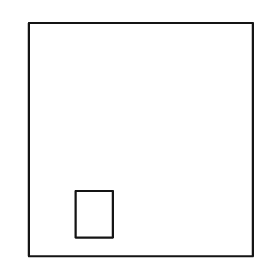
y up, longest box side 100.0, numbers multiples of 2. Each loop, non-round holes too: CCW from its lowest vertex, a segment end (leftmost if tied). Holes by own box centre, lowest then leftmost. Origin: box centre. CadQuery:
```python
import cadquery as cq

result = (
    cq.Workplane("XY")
    .moveTo(-48.0, -50.0)
    .lineTo(48.0, -50.0)
    .lineTo(48.0, 50.0)
    .lineTo(-48.0, 50.0)
    .close()
    .moveTo(-28.0, -42.0)
    .lineTo(-12.0, -42.0)
    .lineTo(-12.0, -22.0)
    .lineTo(-28.0, -22.0)
    .close()
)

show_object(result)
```